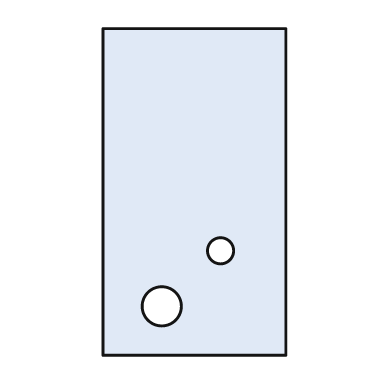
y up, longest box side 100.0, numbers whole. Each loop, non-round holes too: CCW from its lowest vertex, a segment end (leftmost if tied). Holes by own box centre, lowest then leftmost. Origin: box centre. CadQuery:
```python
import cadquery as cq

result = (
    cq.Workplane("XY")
    .moveTo(-28.0, -50.0)
    .lineTo(28.0, -50.0)
    .lineTo(28.0, 50.0)
    .lineTo(-28.0, 50.0)
    .close()
    .moveTo(-10.0, -35.0)
    .circle(6.0)
    .moveTo(8.0, -18.0)
    .circle(4.0)
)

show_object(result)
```